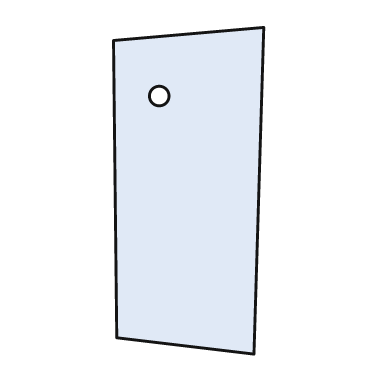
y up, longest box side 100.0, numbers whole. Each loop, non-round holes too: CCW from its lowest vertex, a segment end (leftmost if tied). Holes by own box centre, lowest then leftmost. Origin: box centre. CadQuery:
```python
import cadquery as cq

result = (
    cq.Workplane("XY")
    .moveTo(20.0, -50.0)
    .lineTo(23.0, 50.0)
    .lineTo(-23.0, 46.0)
    .lineTo(-22.0, -45.0)
    .close()
    .moveTo(-9.0, 29.0)
    .circle(3.0)
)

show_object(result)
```